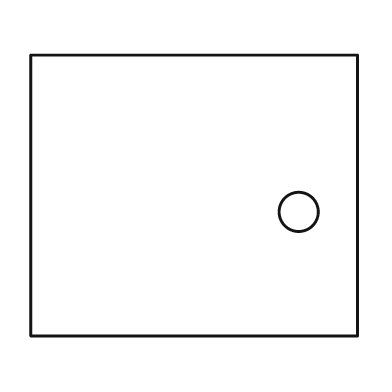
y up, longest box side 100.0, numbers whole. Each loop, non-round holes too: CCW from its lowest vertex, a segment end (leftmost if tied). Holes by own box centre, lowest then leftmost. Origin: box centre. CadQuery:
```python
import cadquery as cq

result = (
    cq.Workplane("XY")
    .moveTo(-50.0, -43.0)
    .lineTo(50.0, -43.0)
    .lineTo(50.0, 43.0)
    .lineTo(-50.0, 43.0)
    .close()
    .moveTo(32.0, -5.0)
    .circle(6.0)
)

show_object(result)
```